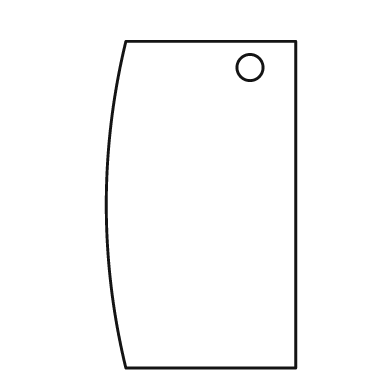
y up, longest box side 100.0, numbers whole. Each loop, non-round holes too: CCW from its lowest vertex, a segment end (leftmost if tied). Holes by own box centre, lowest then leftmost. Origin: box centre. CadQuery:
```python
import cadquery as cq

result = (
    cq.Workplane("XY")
    .moveTo(-23.0, -50.0)
    .lineTo(29.0, -50.0)
    .lineTo(29.0, 50.0)
    .lineTo(-23.0, 50.0)
    .threePointArc((-29.0, 0.0), (-23.0, -50.0))
    .close()
    .moveTo(15.0, 42.0)
    .circle(4.0)
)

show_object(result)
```